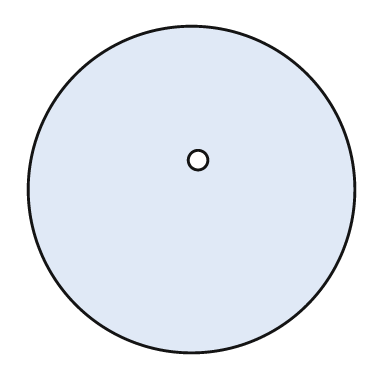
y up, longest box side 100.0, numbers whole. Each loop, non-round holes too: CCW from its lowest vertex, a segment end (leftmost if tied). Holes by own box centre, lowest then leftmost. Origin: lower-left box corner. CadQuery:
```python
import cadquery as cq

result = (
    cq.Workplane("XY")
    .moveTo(50.0, 50.0)
    .circle(50.0)
    .moveTo(52.0, 59.0)
    .circle(3.0)
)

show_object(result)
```